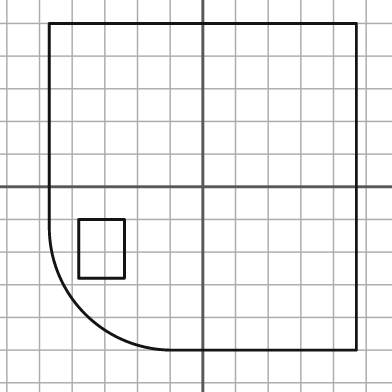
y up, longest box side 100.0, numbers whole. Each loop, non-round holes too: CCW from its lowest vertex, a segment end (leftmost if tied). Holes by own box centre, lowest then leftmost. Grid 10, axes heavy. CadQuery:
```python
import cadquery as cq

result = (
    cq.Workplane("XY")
    .moveTo(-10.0, -50.0)
    .lineTo(47.0, -50.0)
    .lineTo(47.0, 50.0)
    .lineTo(-47.0, 50.0)
    .lineTo(-47.0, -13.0)
    .threePointArc((-36.0, -39.0), (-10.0, -50.0))
    .close()
    .moveTo(-38.0, -28.0)
    .lineTo(-24.0, -28.0)
    .lineTo(-24.0, -10.0)
    .lineTo(-38.0, -10.0)
    .close()
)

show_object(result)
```